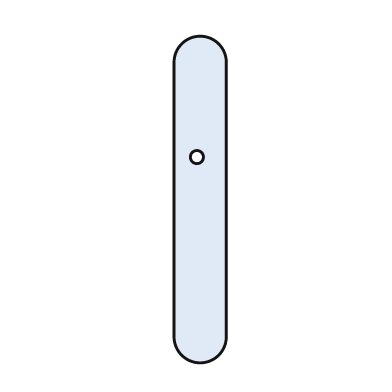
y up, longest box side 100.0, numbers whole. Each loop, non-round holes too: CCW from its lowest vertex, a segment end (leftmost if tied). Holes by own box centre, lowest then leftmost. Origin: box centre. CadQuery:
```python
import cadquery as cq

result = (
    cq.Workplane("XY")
    .moveTo(-8.0, -42.0)
    .threePointArc((0.0, -50.0), (8.0, -42.0))
    .lineTo(8.0, 42.0)
    .threePointArc((0.0, 50.0), (-8.0, 42.0))
    .close()
    .moveTo(-1.0, 13.0)
    .circle(2.0)
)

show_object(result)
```